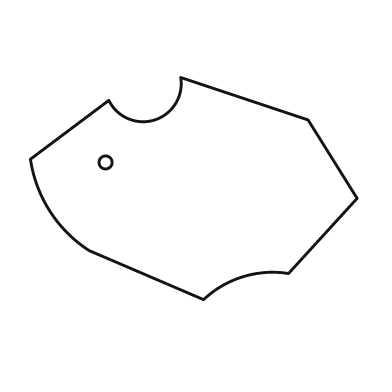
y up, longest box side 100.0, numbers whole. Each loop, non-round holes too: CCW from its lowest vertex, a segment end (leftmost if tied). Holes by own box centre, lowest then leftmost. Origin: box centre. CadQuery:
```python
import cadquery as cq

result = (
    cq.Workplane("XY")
    .moveTo(3.0, -34.0)
    .threePointArc((15.0, -27.0), (29.0, -26.0))
    .lineTo(50.0, -3.0)
    .lineTo(35.0, 21.0)
    .lineTo(-4.0, 34.0)
    .threePointArc((-12.0, 21.0), (-26.0, 27.0))
    .lineTo(-50.0, 9.0)
    .threePointArc((-44.0, -7.0), (-32.0, -19.0))
    .close()
    .moveTo(-27.0, 8.0)
    .circle(2.0)
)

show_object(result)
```